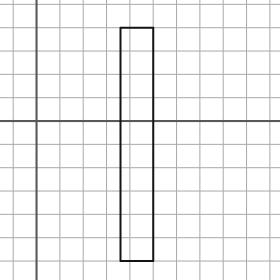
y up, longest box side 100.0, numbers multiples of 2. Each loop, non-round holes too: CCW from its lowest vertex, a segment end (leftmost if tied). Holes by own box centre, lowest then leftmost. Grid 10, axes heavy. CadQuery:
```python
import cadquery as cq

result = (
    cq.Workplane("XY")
    .moveTo(36.0, -60.0)
    .lineTo(50.0, -60.0)
    .lineTo(50.0, 40.0)
    .lineTo(36.0, 40.0)
    .close()
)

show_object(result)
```